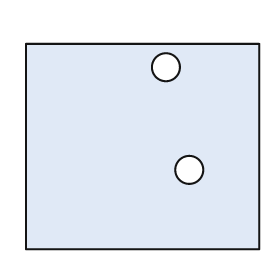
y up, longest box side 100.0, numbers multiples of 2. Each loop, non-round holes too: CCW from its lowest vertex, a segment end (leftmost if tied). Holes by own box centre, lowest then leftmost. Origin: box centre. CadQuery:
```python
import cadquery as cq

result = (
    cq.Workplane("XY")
    .moveTo(-50.0, -44.0)
    .lineTo(50.0, -44.0)
    .lineTo(50.0, 44.0)
    .lineTo(-50.0, 44.0)
    .close()
    .moveTo(20.0, -10.0)
    .circle(6.0)
    .moveTo(10.0, 34.0)
    .circle(6.0)
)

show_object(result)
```